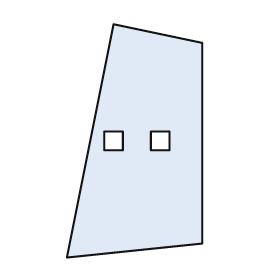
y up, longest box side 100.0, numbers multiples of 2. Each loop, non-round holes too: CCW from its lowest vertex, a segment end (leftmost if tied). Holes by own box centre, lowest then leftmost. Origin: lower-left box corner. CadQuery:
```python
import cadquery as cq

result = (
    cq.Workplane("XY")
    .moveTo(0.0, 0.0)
    .lineTo(58.0, 6.0)
    .lineTo(58.0, 92.0)
    .lineTo(20.0, 100.0)
    .close()
    .moveTo(16.0, 46.0)
    .lineTo(24.0, 46.0)
    .lineTo(24.0, 54.0)
    .lineTo(16.0, 54.0)
    .close()
    .moveTo(36.0, 46.0)
    .lineTo(44.0, 46.0)
    .lineTo(44.0, 54.0)
    .lineTo(36.0, 54.0)
    .close()
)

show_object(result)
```